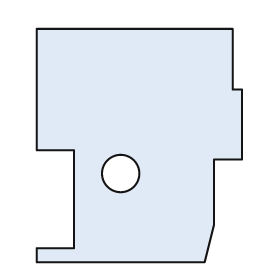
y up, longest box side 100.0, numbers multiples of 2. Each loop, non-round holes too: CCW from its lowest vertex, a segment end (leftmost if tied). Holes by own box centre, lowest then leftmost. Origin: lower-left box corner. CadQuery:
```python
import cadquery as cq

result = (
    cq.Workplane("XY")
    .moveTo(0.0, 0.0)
    .lineTo(72.0, 0.0)
    .lineTo(76.0, 16.0)
    .lineTo(76.0, 44.0)
    .lineTo(88.0, 44.0)
    .lineTo(88.0, 74.0)
    .lineTo(84.0, 74.0)
    .lineTo(84.0, 100.0)
    .lineTo(0.0, 100.0)
    .lineTo(0.0, 48.0)
    .lineTo(16.0, 48.0)
    .lineTo(16.0, 6.0)
    .lineTo(0.0, 6.0)
    .close()
    .moveTo(36.0, 38.0)
    .circle(8.0)
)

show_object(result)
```